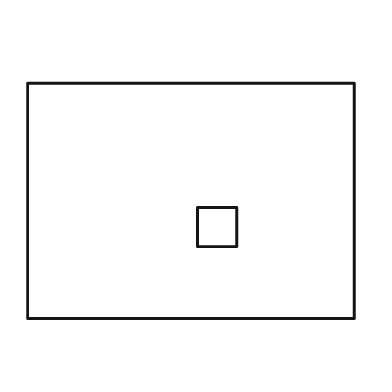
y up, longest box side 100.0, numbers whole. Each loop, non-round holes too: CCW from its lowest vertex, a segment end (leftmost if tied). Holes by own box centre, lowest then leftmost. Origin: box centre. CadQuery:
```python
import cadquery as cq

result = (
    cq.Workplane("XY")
    .moveTo(-50.0, -36.0)
    .lineTo(50.0, -36.0)
    .lineTo(50.0, 36.0)
    .lineTo(-50.0, 36.0)
    .close()
    .moveTo(2.0, -14.0)
    .lineTo(14.0, -14.0)
    .lineTo(14.0, -2.0)
    .lineTo(2.0, -2.0)
    .close()
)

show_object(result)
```